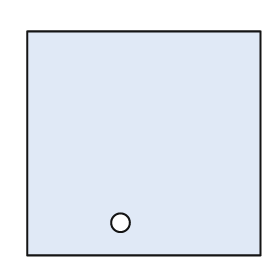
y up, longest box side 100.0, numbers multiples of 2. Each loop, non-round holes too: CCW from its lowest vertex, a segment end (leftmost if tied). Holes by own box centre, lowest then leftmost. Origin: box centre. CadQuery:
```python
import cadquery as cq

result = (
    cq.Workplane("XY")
    .moveTo(-50.0, -48.0)
    .lineTo(50.0, -48.0)
    .lineTo(50.0, 48.0)
    .lineTo(-50.0, 48.0)
    .close()
    .moveTo(-10.0, -34.0)
    .circle(4.0)
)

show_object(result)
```